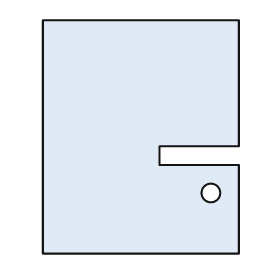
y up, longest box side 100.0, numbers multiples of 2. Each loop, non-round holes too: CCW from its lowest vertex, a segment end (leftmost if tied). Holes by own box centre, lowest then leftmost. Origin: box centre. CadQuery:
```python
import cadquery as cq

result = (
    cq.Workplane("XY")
    .moveTo(-42.0, -50.0)
    .lineTo(42.0, -50.0)
    .lineTo(42.0, -12.0)
    .lineTo(8.0, -12.0)
    .lineTo(8.0, -4.0)
    .lineTo(42.0, -4.0)
    .lineTo(42.0, 50.0)
    .lineTo(-42.0, 50.0)
    .close()
    .moveTo(30.0, -24.0)
    .circle(4.0)
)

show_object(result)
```